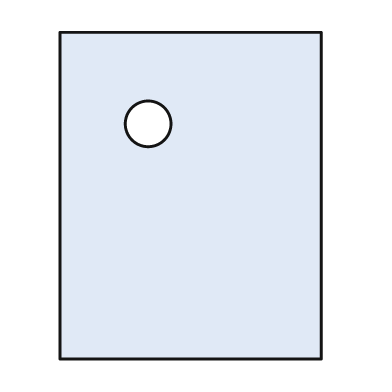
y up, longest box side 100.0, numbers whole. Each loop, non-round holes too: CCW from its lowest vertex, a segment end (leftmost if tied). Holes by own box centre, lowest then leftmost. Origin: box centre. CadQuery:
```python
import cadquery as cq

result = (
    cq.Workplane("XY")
    .moveTo(-40.0, -50.0)
    .lineTo(40.0, -50.0)
    .lineTo(40.0, 50.0)
    .lineTo(-40.0, 50.0)
    .close()
    .moveTo(-13.0, 22.0)
    .circle(7.0)
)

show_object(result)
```